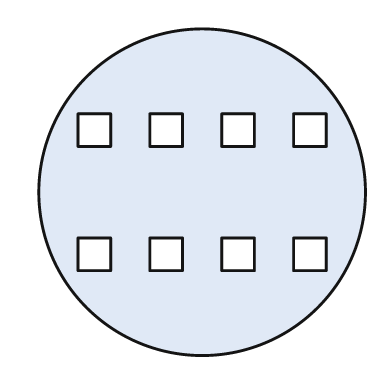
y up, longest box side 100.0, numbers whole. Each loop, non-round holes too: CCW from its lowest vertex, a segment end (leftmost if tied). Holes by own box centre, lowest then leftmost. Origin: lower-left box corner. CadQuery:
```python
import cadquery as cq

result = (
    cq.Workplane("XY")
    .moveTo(50.0, 50.0)
    .circle(50.0)
    .moveTo(12.0, 26.0)
    .lineTo(22.0, 26.0)
    .lineTo(22.0, 36.0)
    .lineTo(12.0, 36.0)
    .close()
    .moveTo(34.0, 26.0)
    .lineTo(44.0, 26.0)
    .lineTo(44.0, 36.0)
    .lineTo(34.0, 36.0)
    .close()
    .moveTo(56.0, 26.0)
    .lineTo(66.0, 26.0)
    .lineTo(66.0, 36.0)
    .lineTo(56.0, 36.0)
    .close()
    .moveTo(78.0, 26.0)
    .lineTo(88.0, 26.0)
    .lineTo(88.0, 36.0)
    .lineTo(78.0, 36.0)
    .close()
    .moveTo(12.0, 64.0)
    .lineTo(22.0, 64.0)
    .lineTo(22.0, 74.0)
    .lineTo(12.0, 74.0)
    .close()
    .moveTo(34.0, 64.0)
    .lineTo(44.0, 64.0)
    .lineTo(44.0, 74.0)
    .lineTo(34.0, 74.0)
    .close()
    .moveTo(56.0, 64.0)
    .lineTo(66.0, 64.0)
    .lineTo(66.0, 74.0)
    .lineTo(56.0, 74.0)
    .close()
    .moveTo(78.0, 64.0)
    .lineTo(88.0, 64.0)
    .lineTo(88.0, 74.0)
    .lineTo(78.0, 74.0)
    .close()
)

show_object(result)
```